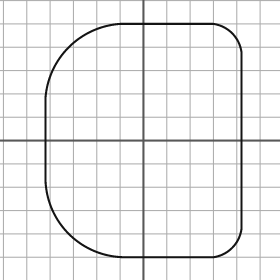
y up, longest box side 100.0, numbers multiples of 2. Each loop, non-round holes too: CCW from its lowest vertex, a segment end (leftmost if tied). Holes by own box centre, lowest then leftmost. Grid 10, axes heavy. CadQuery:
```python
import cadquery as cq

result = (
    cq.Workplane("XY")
    .moveTo(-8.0, -50.0)
    .lineTo(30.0, -50.0)
    .threePointArc((38.0, -46.0), (42.0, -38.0))
    .lineTo(42.0, 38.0)
    .threePointArc((38.0, 46.0), (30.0, 50.0))
    .lineTo(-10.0, 50.0)
    .threePointArc((-32.0, 40.0), (-42.0, 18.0))
    .lineTo(-42.0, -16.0)
    .threePointArc((-32.0, -40.0), (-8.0, -50.0))
    .close()
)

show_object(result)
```